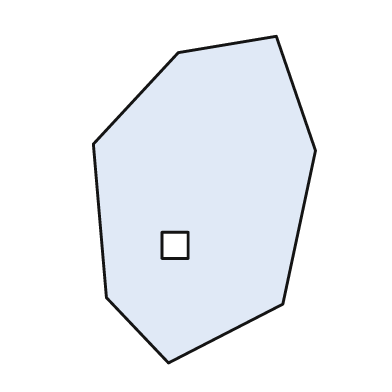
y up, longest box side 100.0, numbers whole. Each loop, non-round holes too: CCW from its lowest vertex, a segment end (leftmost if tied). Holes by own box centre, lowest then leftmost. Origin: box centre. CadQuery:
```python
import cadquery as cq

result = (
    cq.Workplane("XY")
    .moveTo(-11.0, -50.0)
    .lineTo(24.0, -32.0)
    .lineTo(34.0, 15.0)
    .lineTo(22.0, 50.0)
    .lineTo(-8.0, 45.0)
    .lineTo(-34.0, 17.0)
    .lineTo(-30.0, -30.0)
    .close()
    .moveTo(-13.0, -18.0)
    .lineTo(-5.0, -18.0)
    .lineTo(-5.0, -10.0)
    .lineTo(-13.0, -10.0)
    .close()
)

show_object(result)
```